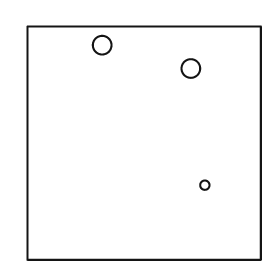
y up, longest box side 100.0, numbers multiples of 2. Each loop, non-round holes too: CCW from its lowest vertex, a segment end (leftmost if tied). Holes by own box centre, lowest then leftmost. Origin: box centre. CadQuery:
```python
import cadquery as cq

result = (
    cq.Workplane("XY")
    .moveTo(-50.0, -50.0)
    .lineTo(50.0, -50.0)
    .lineTo(50.0, 50.0)
    .lineTo(-50.0, 50.0)
    .close()
    .moveTo(26.0, -18.0)
    .circle(2.0)
    .moveTo(20.0, 32.0)
    .circle(4.0)
    .moveTo(-18.0, 42.0)
    .circle(4.0)
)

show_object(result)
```